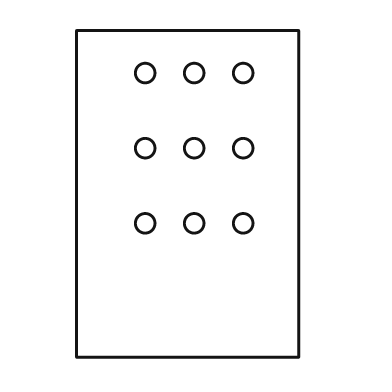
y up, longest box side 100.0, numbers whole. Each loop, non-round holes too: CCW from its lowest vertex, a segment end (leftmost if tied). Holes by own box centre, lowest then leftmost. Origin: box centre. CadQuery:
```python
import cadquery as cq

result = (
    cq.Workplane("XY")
    .moveTo(-34.0, -50.0)
    .lineTo(34.0, -50.0)
    .lineTo(34.0, 50.0)
    .lineTo(-34.0, 50.0)
    .close()
    .moveTo(-13.0, -9.0)
    .circle(3.0)
    .moveTo(2.0, -9.0)
    .circle(3.0)
    .moveTo(17.0, -9.0)
    .circle(3.0)
    .moveTo(-13.0, 14.0)
    .circle(3.0)
    .moveTo(2.0, 14.0)
    .circle(3.0)
    .moveTo(17.0, 14.0)
    .circle(3.0)
    .moveTo(-13.0, 37.0)
    .circle(3.0)
    .moveTo(2.0, 37.0)
    .circle(3.0)
    .moveTo(17.0, 37.0)
    .circle(3.0)
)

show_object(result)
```